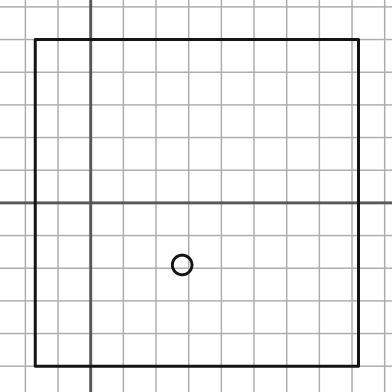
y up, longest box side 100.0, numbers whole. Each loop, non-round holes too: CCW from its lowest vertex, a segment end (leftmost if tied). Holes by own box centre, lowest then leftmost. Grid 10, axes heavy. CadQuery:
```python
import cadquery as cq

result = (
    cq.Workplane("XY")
    .moveTo(-17.0, -50.0)
    .lineTo(82.0, -50.0)
    .lineTo(82.0, 50.0)
    .lineTo(-17.0, 50.0)
    .close()
    .moveTo(28.0, -19.0)
    .circle(3.0)
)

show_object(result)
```